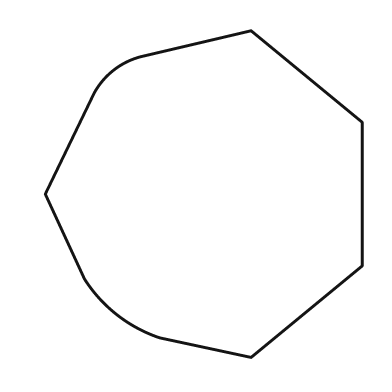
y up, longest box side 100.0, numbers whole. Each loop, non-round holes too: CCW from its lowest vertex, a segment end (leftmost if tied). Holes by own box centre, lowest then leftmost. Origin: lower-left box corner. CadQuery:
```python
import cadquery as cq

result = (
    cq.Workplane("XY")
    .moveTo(63.0, 0.0)
    .lineTo(97.0, 28.0)
    .lineTo(97.0, 72.0)
    .lineTo(63.0, 100.0)
    .lineTo(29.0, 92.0)
    .threePointArc((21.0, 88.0), (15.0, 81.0))
    .lineTo(0.0, 50.0)
    .lineTo(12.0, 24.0)
    .threePointArc((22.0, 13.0), (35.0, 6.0))
    .close()
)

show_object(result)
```